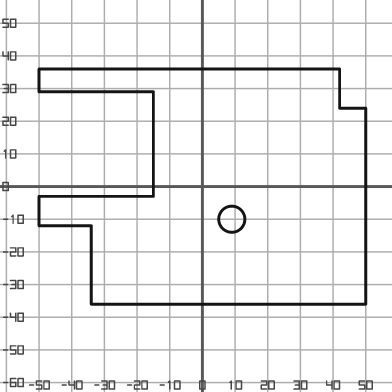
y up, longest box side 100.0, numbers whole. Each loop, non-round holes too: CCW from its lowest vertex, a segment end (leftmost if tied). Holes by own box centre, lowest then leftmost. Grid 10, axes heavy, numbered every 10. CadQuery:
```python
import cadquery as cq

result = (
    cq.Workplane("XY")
    .moveTo(-34.0, -36.0)
    .lineTo(50.0, -36.0)
    .lineTo(50.0, 24.0)
    .lineTo(42.0, 24.0)
    .lineTo(42.0, 36.0)
    .lineTo(-50.0, 36.0)
    .lineTo(-50.0, 29.0)
    .lineTo(-15.0, 29.0)
    .lineTo(-15.0, -3.0)
    .lineTo(-50.0, -3.0)
    .lineTo(-50.0, -12.0)
    .lineTo(-34.0, -12.0)
    .close()
    .moveTo(9.0, -10.0)
    .circle(4.0)
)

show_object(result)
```